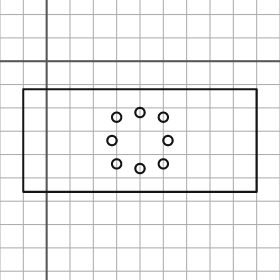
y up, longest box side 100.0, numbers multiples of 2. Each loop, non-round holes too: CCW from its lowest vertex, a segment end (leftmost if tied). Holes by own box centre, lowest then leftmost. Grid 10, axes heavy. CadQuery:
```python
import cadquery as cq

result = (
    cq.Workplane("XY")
    .moveTo(-10.0, -56.0)
    .lineTo(90.0, -56.0)
    .lineTo(90.0, -12.0)
    .lineTo(-10.0, -12.0)
    .close()
    .moveTo(40.0, -46.0)
    .circle(2.0)
    .moveTo(30.0, -44.0)
    .circle(2.0)
    .moveTo(50.0, -44.0)
    .circle(2.0)
    .moveTo(28.0, -34.0)
    .circle(2.0)
    .moveTo(52.0, -34.0)
    .circle(2.0)
    .moveTo(30.0, -24.0)
    .circle(2.0)
    .moveTo(50.0, -24.0)
    .circle(2.0)
    .moveTo(40.0, -22.0)
    .circle(2.0)
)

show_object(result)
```